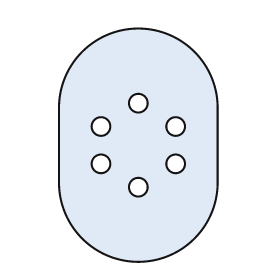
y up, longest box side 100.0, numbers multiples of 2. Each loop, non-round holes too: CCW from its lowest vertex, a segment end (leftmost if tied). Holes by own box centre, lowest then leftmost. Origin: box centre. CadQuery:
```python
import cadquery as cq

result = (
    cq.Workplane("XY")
    .moveTo(-34.0, -16.0)
    .threePointArc((0.0, -50.0), (34.0, -16.0))
    .lineTo(34.0, 16.0)
    .threePointArc((0.0, 50.0), (-34.0, 16.0))
    .close()
    .moveTo(0.0, -18.0)
    .circle(4.0)
    .moveTo(-16.0, -8.0)
    .circle(4.0)
    .moveTo(16.0, -8.0)
    .circle(4.0)
    .moveTo(-16.0, 8.0)
    .circle(4.0)
    .moveTo(16.0, 8.0)
    .circle(4.0)
    .moveTo(0.0, 18.0)
    .circle(4.0)
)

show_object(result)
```